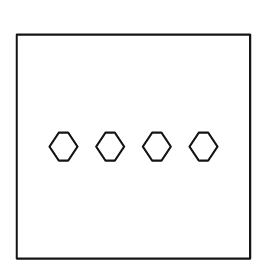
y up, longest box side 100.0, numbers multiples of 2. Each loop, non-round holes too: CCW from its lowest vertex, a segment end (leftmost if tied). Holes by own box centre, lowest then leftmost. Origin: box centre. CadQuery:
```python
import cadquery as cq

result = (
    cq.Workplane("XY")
    .moveTo(-50.0, -48.0)
    .lineTo(50.0, -48.0)
    .lineTo(50.0, 48.0)
    .lineTo(-50.0, 48.0)
    .close()
    .moveTo(-32.0, -6.0)
    .lineTo(-28.0, -6.0)
    .lineTo(-24.0, 0.0)
    .lineTo(-28.0, 6.0)
    .lineTo(-32.0, 6.0)
    .lineTo(-36.0, 0.0)
    .close()
    .moveTo(-12.0, -6.0)
    .lineTo(-8.0, -6.0)
    .lineTo(-4.0, 0.0)
    .lineTo(-8.0, 6.0)
    .lineTo(-12.0, 6.0)
    .lineTo(-16.0, 0.0)
    .close()
    .moveTo(8.0, -6.0)
    .lineTo(12.0, -6.0)
    .lineTo(16.0, 0.0)
    .lineTo(12.0, 6.0)
    .lineTo(8.0, 6.0)
    .lineTo(4.0, 0.0)
    .close()
    .moveTo(28.0, -6.0)
    .lineTo(32.0, -6.0)
    .lineTo(36.0, 0.0)
    .lineTo(32.0, 6.0)
    .lineTo(28.0, 6.0)
    .lineTo(24.0, 0.0)
    .close()
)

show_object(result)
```